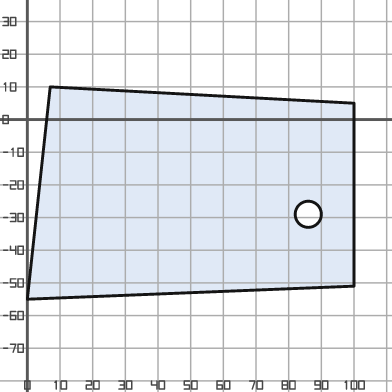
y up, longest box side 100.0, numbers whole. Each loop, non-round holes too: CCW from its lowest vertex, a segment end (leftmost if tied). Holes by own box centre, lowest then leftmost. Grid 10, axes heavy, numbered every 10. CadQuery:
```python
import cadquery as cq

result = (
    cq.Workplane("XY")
    .moveTo(0.0, -55.0)
    .lineTo(100.0, -51.0)
    .lineTo(100.0, 5.0)
    .lineTo(7.0, 10.0)
    .close()
    .moveTo(86.0, -29.0)
    .circle(4.0)
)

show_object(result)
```